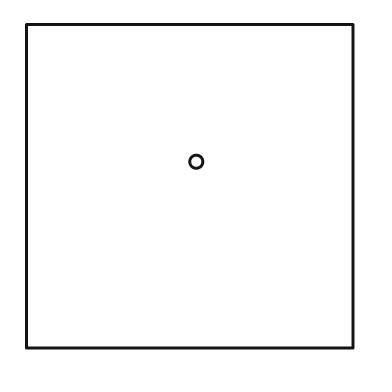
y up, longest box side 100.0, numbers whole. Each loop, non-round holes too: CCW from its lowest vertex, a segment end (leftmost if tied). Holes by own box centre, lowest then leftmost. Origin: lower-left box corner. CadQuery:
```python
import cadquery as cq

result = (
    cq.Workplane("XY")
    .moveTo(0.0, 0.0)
    .lineTo(100.0, 0.0)
    .lineTo(100.0, 99.0)
    .lineTo(0.0, 99.0)
    .close()
    .moveTo(52.0, 57.0)
    .circle(2.0)
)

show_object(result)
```